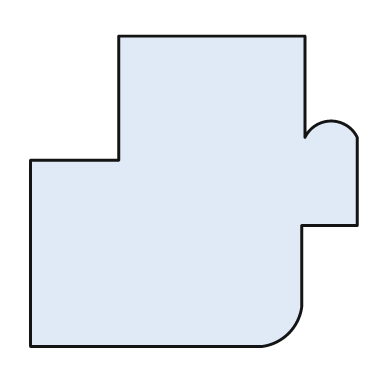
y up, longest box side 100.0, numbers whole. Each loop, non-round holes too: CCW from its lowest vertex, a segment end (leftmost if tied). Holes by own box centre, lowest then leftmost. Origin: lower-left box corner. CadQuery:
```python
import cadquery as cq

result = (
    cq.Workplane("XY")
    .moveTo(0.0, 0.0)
    .lineTo(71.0, 0.0)
    .threePointArc((79.0, 4.0), (83.0, 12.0))
    .lineTo(83.0, 37.0)
    .lineTo(100.0, 37.0)
    .lineTo(100.0, 64.0)
    .threePointArc((92.0, 69.0), (84.0, 64.0))
    .lineTo(84.0, 95.0)
    .lineTo(27.0, 95.0)
    .lineTo(27.0, 57.0)
    .lineTo(0.0, 57.0)
    .close()
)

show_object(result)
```